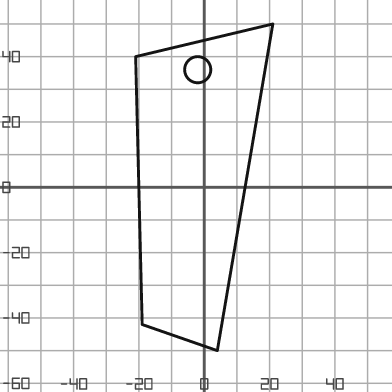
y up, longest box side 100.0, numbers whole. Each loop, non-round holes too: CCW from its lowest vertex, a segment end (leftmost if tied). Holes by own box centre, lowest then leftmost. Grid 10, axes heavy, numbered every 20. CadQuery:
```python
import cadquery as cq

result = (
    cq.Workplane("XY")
    .moveTo(4.0, -50.0)
    .lineTo(21.0, 50.0)
    .lineTo(-21.0, 40.0)
    .lineTo(-19.0, -42.0)
    .close()
    .moveTo(-2.0, 36.0)
    .circle(4.0)
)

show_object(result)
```